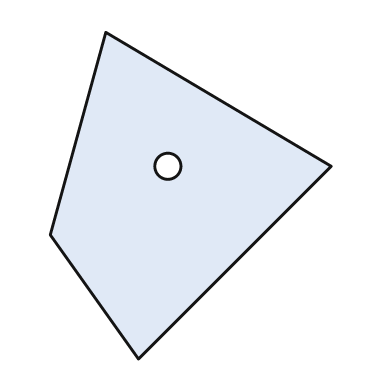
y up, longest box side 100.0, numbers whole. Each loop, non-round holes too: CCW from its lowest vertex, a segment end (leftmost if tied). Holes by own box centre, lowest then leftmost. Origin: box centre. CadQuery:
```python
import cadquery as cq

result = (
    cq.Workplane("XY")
    .moveTo(-16.0, -50.0)
    .lineTo(43.0, 9.0)
    .lineTo(-26.0, 50.0)
    .lineTo(-43.0, -12.0)
    .close()
    .moveTo(-7.0, 9.0)
    .circle(4.0)
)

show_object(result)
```